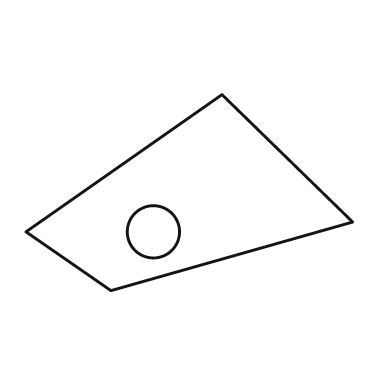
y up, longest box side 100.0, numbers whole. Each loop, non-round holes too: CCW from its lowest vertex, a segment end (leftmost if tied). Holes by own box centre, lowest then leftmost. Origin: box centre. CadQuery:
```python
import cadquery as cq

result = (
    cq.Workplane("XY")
    .moveTo(-24.0, -30.0)
    .lineTo(50.0, -9.0)
    .lineTo(10.0, 30.0)
    .lineTo(-50.0, -12.0)
    .close()
    .moveTo(-11.0, -12.0)
    .circle(8.0)
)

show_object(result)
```